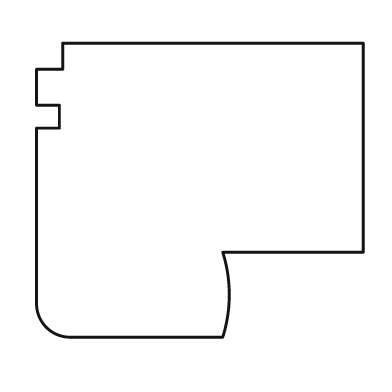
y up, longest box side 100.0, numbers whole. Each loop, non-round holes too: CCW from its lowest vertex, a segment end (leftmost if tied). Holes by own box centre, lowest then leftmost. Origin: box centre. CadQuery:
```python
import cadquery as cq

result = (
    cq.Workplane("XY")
    .moveTo(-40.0, -45.0)
    .lineTo(7.0, -45.0)
    .threePointArc((9.0, -32.0), (7.0, -19.0))
    .lineTo(50.0, -19.0)
    .lineTo(50.0, 45.0)
    .lineTo(-42.0, 45.0)
    .lineTo(-42.0, 37.0)
    .lineTo(-50.0, 37.0)
    .lineTo(-50.0, 26.0)
    .lineTo(-43.0, 26.0)
    .lineTo(-43.0, 19.0)
    .lineTo(-50.0, 19.0)
    .lineTo(-50.0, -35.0)
    .threePointArc((-47.0, -42.0), (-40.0, -45.0))
    .close()
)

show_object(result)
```